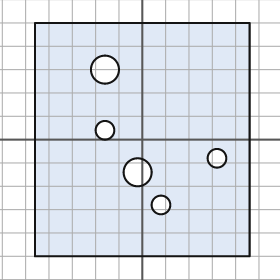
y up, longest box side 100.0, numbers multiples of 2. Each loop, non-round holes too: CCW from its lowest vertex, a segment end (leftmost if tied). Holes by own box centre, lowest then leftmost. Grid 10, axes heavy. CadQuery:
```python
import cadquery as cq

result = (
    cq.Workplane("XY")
    .moveTo(-46.0, -50.0)
    .lineTo(46.0, -50.0)
    .lineTo(46.0, 50.0)
    .lineTo(-46.0, 50.0)
    .close()
    .moveTo(8.0, -28.0)
    .circle(4.0)
    .moveTo(-2.0, -14.0)
    .circle(6.0)
    .moveTo(32.0, -8.0)
    .circle(4.0)
    .moveTo(-16.0, 4.0)
    .circle(4.0)
    .moveTo(-16.0, 30.0)
    .circle(6.0)
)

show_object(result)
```